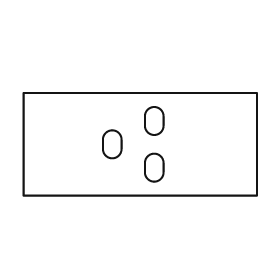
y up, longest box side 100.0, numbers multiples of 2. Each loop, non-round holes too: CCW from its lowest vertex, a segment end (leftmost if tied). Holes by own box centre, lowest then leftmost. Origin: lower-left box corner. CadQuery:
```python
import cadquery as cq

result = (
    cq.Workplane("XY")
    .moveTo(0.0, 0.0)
    .lineTo(100.0, 0.0)
    .lineTo(100.0, 44.0)
    .lineTo(0.0, 44.0)
    .close()
    .moveTo(52.0, 10.0)
    .threePointArc((56.0, 6.0), (60.0, 10.0))
    .lineTo(60.0, 14.0)
    .threePointArc((56.0, 18.0), (52.0, 14.0))
    .close()
    .moveTo(34.0, 20.0)
    .threePointArc((38.0, 16.0), (42.0, 20.0))
    .lineTo(42.0, 24.0)
    .threePointArc((38.0, 28.0), (34.0, 24.0))
    .close()
    .moveTo(52.0, 30.0)
    .threePointArc((56.0, 26.0), (60.0, 30.0))
    .lineTo(60.0, 34.0)
    .threePointArc((56.0, 38.0), (52.0, 34.0))
    .close()
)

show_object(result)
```